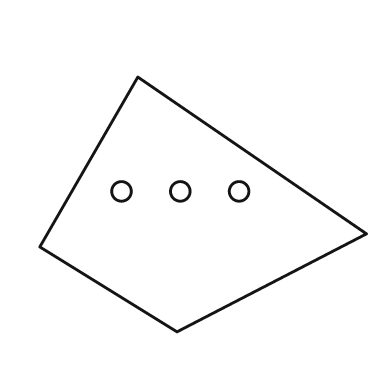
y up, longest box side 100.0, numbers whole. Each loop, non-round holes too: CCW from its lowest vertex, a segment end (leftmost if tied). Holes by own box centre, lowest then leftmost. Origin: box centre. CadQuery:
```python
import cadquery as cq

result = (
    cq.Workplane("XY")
    .moveTo(-8.0, -39.0)
    .lineTo(50.0, -9.0)
    .lineTo(-20.0, 39.0)
    .lineTo(-50.0, -13.0)
    .close()
    .moveTo(-25.0, 4.0)
    .circle(3.0)
    .moveTo(-7.0, 4.0)
    .circle(3.0)
    .moveTo(11.0, 4.0)
    .circle(3.0)
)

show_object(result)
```